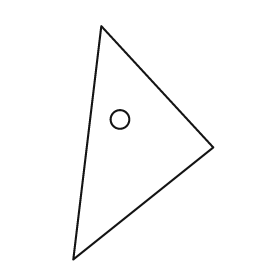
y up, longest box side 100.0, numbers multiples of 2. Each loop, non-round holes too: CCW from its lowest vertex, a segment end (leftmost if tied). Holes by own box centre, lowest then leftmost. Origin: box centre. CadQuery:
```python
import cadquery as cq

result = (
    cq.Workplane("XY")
    .moveTo(-30.0, -50.0)
    .lineTo(30.0, -2.0)
    .lineTo(-18.0, 50.0)
    .close()
    .moveTo(-10.0, 10.0)
    .circle(4.0)
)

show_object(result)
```